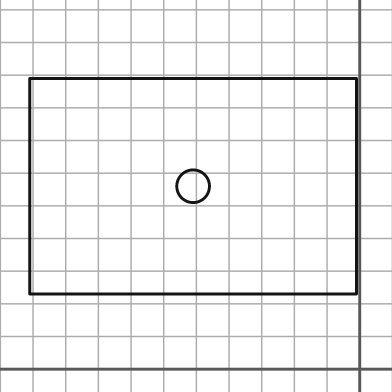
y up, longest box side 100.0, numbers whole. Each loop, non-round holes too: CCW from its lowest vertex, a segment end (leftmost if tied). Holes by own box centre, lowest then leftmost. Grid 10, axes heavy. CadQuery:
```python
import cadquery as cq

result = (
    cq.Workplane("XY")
    .moveTo(-101.0, 23.0)
    .lineTo(-1.0, 23.0)
    .lineTo(-1.0, 89.0)
    .lineTo(-101.0, 89.0)
    .close()
    .moveTo(-51.0, 56.0)
    .circle(5.0)
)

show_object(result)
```